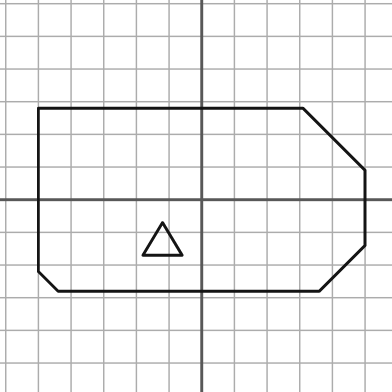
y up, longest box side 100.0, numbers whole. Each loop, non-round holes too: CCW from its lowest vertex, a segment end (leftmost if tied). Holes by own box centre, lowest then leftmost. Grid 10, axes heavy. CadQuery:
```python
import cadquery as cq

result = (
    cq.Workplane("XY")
    .moveTo(-44.0, -28.0)
    .lineTo(36.0, -28.0)
    .lineTo(50.0, -14.0)
    .lineTo(50.0, 9.0)
    .lineTo(31.0, 28.0)
    .lineTo(-50.0, 28.0)
    .lineTo(-50.0, -22.0)
    .close()
    .moveTo(-18.0, -17.0)
    .lineTo(-6.0, -17.0)
    .lineTo(-12.0, -7.0)
    .close()
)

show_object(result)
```